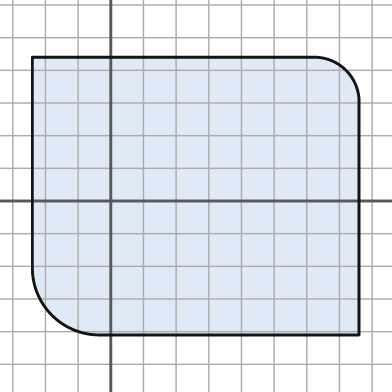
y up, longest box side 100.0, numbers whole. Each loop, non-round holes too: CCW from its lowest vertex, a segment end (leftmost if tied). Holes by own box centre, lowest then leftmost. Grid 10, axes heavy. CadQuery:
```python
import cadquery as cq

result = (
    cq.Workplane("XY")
    .moveTo(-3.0, -41.0)
    .lineTo(76.0, -41.0)
    .lineTo(76.0, 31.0)
    .threePointArc((72.0, 40.0), (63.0, 44.0))
    .lineTo(-24.0, 44.0)
    .lineTo(-24.0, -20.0)
    .threePointArc((-18.0, -35.0), (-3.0, -41.0))
    .close()
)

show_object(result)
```